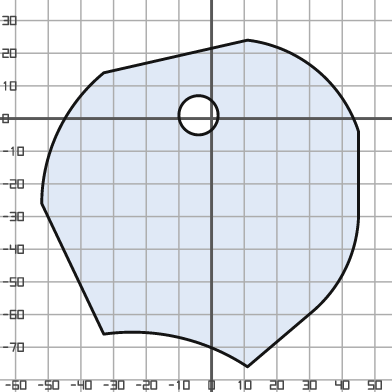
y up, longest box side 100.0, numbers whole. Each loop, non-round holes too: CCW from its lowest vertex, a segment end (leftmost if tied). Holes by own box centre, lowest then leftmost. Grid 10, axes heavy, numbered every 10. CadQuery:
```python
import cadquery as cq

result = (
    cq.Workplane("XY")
    .moveTo(11.0, -76.0)
    .lineTo(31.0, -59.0)
    .threePointArc((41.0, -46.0), (45.0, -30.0))
    .lineTo(45.0, -4.0)
    .threePointArc((32.0, 15.0), (11.0, 24.0))
    .lineTo(-33.0, 14.0)
    .threePointArc((-47.0, -4.0), (-52.0, -26.0))
    .lineTo(-33.0, -66.0)
    .threePointArc((-10.0, -67.0), (11.0, -76.0))
    .close()
    .moveTo(-4.0, 1.0)
    .circle(6.0)
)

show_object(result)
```